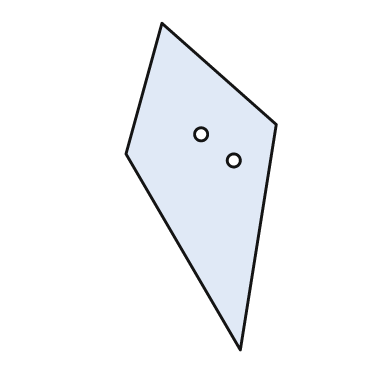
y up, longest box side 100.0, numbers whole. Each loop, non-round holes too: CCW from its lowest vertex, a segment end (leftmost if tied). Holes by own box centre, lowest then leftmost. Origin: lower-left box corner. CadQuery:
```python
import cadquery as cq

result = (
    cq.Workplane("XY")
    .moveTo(35.0, 0.0)
    .lineTo(46.0, 69.0)
    .lineTo(11.0, 100.0)
    .lineTo(0.0, 60.0)
    .close()
    .moveTo(33.0, 58.0)
    .circle(2.0)
    .moveTo(23.0, 66.0)
    .circle(2.0)
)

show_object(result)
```